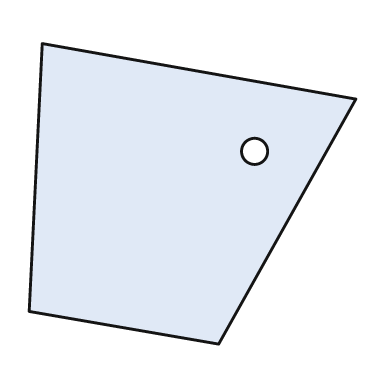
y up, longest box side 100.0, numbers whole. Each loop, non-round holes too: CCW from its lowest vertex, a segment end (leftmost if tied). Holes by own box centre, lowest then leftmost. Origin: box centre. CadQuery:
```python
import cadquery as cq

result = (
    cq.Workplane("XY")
    .moveTo(8.0, -46.0)
    .lineTo(50.0, 29.0)
    .lineTo(-46.0, 46.0)
    .lineTo(-50.0, -36.0)
    .close()
    .moveTo(19.0, 13.0)
    .circle(4.0)
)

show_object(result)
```